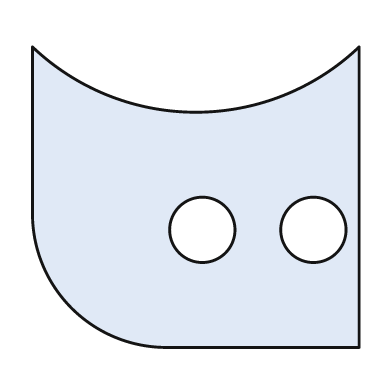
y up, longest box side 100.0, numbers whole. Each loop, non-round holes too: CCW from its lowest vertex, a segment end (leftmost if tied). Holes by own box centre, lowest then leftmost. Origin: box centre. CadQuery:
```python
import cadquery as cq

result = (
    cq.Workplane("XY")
    .moveTo(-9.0, -46.0)
    .lineTo(50.0, -46.0)
    .lineTo(50.0, 46.0)
    .threePointArc((0.0, 26.0), (-50.0, 46.0))
    .lineTo(-50.0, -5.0)
    .threePointArc((-38.0, -34.0), (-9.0, -46.0))
    .close()
    .moveTo(2.0, -10.0)
    .circle(10.0)
    .moveTo(36.0, -10.0)
    .circle(10.0)
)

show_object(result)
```